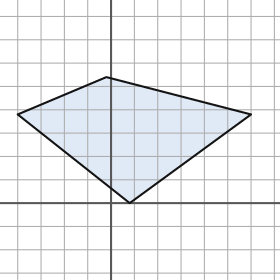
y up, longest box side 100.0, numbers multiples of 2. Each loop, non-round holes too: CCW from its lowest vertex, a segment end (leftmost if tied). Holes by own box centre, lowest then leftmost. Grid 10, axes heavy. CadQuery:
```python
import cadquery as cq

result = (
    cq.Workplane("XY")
    .moveTo(8.0, 0.0)
    .lineTo(60.0, 38.0)
    .lineTo(-2.0, 54.0)
    .lineTo(-40.0, 38.0)
    .close()
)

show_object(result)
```